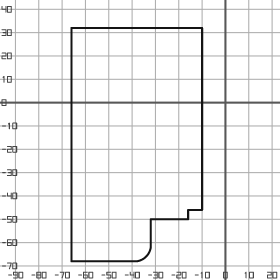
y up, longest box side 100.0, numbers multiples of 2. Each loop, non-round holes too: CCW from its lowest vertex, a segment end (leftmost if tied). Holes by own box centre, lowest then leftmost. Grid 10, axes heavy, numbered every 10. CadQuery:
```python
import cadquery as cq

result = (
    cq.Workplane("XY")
    .moveTo(-66.0, -68.0)
    .lineTo(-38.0, -68.0)
    .threePointArc((-34.0, -66.0), (-32.0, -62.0))
    .lineTo(-32.0, -50.0)
    .lineTo(-16.0, -50.0)
    .lineTo(-16.0, -46.0)
    .lineTo(-10.0, -46.0)
    .lineTo(-10.0, 32.0)
    .lineTo(-66.0, 32.0)
    .close()
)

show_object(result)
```